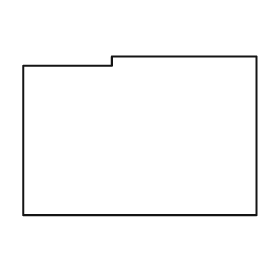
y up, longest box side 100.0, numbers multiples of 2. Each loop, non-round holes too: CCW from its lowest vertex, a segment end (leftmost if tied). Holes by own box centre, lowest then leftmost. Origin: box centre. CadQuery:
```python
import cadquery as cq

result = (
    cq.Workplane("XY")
    .moveTo(-50.0, -34.0)
    .lineTo(50.0, -34.0)
    .lineTo(50.0, 34.0)
    .lineTo(-12.0, 34.0)
    .lineTo(-12.0, 30.0)
    .lineTo(-50.0, 30.0)
    .close()
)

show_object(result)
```